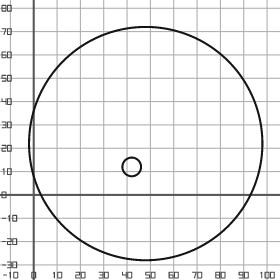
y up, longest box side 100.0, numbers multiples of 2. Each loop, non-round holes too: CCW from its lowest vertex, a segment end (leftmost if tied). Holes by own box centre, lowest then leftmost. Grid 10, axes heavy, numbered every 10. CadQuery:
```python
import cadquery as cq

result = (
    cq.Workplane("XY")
    .moveTo(48.0, 22.0)
    .circle(50.0)
    .moveTo(42.0, 12.0)
    .circle(4.0)
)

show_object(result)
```